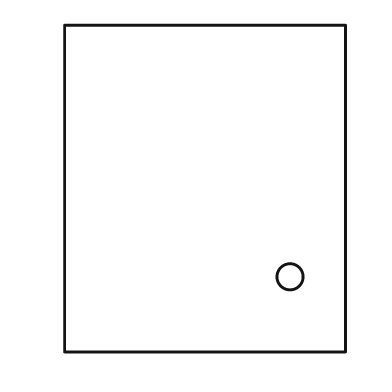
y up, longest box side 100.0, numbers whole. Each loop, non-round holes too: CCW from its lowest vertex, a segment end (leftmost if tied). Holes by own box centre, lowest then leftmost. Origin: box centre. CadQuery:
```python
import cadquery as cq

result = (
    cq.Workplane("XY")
    .moveTo(-43.0, -50.0)
    .lineTo(43.0, -50.0)
    .lineTo(43.0, 50.0)
    .lineTo(-43.0, 50.0)
    .close()
    .moveTo(26.0, -27.0)
    .circle(4.0)
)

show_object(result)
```